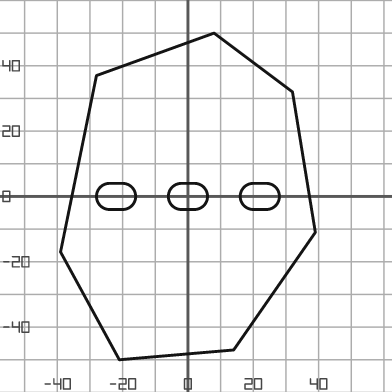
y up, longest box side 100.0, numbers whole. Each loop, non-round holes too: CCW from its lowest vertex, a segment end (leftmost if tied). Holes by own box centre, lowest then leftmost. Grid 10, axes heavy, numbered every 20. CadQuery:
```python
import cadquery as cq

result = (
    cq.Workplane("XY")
    .moveTo(-21.0, -50.0)
    .lineTo(14.0, -47.0)
    .lineTo(39.0, -11.0)
    .lineTo(32.0, 32.0)
    .lineTo(8.0, 50.0)
    .lineTo(-28.0, 37.0)
    .lineTo(-39.0, -17.0)
    .close()
    .moveTo(-24.0, -4.0)
    .lineTo(-20.0, -4.0)
    .threePointArc((-16.0, 0.0), (-20.0, 4.0))
    .lineTo(-24.0, 4.0)
    .threePointArc((-28.0, 0.0), (-24.0, -4.0))
    .close()
    .moveTo(-2.0, -4.0)
    .lineTo(2.0, -4.0)
    .threePointArc((6.0, 0.0), (2.0, 4.0))
    .lineTo(-2.0, 4.0)
    .threePointArc((-6.0, 0.0), (-2.0, -4.0))
    .close()
    .moveTo(20.0, -4.0)
    .lineTo(24.0, -4.0)
    .threePointArc((28.0, 0.0), (24.0, 4.0))
    .lineTo(20.0, 4.0)
    .threePointArc((16.0, 0.0), (20.0, -4.0))
    .close()
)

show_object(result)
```